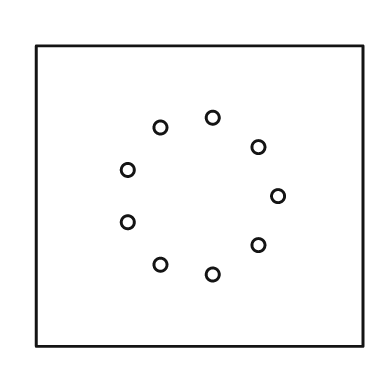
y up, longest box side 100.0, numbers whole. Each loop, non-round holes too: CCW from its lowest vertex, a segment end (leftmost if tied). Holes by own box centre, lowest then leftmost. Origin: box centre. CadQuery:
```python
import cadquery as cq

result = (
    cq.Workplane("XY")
    .moveTo(-50.0, -46.0)
    .lineTo(50.0, -46.0)
    .lineTo(50.0, 46.0)
    .lineTo(-50.0, 46.0)
    .close()
    .moveTo(4.0, -24.0)
    .circle(2.0)
    .moveTo(-12.0, -21.0)
    .circle(2.0)
    .moveTo(18.0, -15.0)
    .circle(2.0)
    .moveTo(-22.0, -8.0)
    .circle(2.0)
    .moveTo(24.0, 0.0)
    .circle(2.0)
    .moveTo(-22.0, 8.0)
    .circle(2.0)
    .moveTo(18.0, 15.0)
    .circle(2.0)
    .moveTo(-12.0, 21.0)
    .circle(2.0)
    .moveTo(4.0, 24.0)
    .circle(2.0)
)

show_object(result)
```